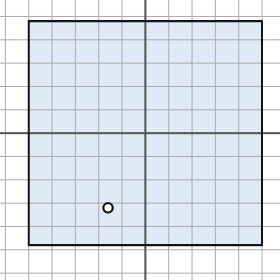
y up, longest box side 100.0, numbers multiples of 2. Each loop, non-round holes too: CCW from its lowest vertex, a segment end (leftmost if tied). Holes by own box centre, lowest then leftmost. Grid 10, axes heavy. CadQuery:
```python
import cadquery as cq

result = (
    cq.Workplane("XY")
    .moveTo(-50.0, -48.0)
    .lineTo(50.0, -48.0)
    .lineTo(50.0, 48.0)
    .lineTo(-50.0, 48.0)
    .close()
    .moveTo(-16.0, -32.0)
    .circle(2.0)
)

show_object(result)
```